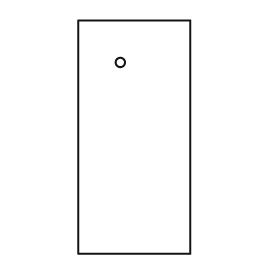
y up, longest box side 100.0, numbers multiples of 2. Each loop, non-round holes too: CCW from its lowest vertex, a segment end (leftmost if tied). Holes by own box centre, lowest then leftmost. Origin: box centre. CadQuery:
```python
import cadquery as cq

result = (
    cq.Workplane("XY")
    .moveTo(-24.0, -50.0)
    .lineTo(24.0, -50.0)
    .lineTo(24.0, 50.0)
    .lineTo(-24.0, 50.0)
    .close()
    .moveTo(-6.0, 32.0)
    .circle(2.0)
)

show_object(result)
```